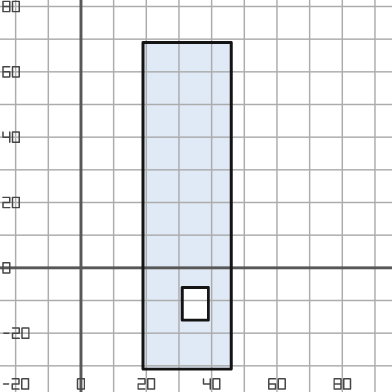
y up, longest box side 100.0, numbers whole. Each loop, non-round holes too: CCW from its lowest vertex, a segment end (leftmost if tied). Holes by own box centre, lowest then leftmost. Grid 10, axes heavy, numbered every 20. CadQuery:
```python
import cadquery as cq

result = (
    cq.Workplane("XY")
    .moveTo(19.0, -31.0)
    .lineTo(46.0, -31.0)
    .lineTo(46.0, 69.0)
    .lineTo(19.0, 69.0)
    .close()
    .moveTo(31.0, -16.0)
    .lineTo(39.0, -16.0)
    .lineTo(39.0, -6.0)
    .lineTo(31.0, -6.0)
    .close()
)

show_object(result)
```